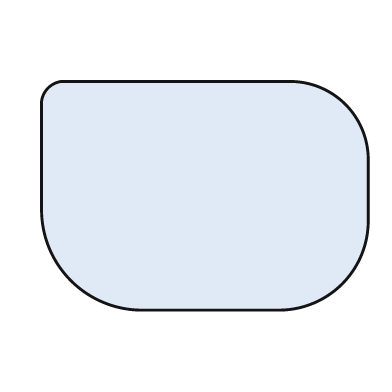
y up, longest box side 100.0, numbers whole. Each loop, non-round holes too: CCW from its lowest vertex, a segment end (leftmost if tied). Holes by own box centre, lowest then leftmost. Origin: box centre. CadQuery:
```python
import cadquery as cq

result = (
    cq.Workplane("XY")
    .moveTo(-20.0, -35.0)
    .lineTo(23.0, -35.0)
    .threePointArc((42.0, -27.0), (50.0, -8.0))
    .lineTo(50.0, 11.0)
    .threePointArc((43.0, 28.0), (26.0, 35.0))
    .lineTo(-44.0, 35.0)
    .threePointArc((-48.0, 33.0), (-50.0, 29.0))
    .lineTo(-50.0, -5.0)
    .threePointArc((-41.0, -26.0), (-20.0, -35.0))
    .close()
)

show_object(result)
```